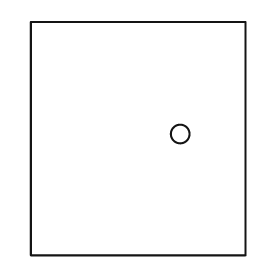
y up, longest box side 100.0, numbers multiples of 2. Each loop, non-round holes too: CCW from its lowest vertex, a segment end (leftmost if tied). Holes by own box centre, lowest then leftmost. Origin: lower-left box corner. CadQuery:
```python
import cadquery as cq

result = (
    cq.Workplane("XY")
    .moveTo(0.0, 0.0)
    .lineTo(92.0, 0.0)
    .lineTo(92.0, 100.0)
    .lineTo(0.0, 100.0)
    .close()
    .moveTo(64.0, 52.0)
    .circle(4.0)
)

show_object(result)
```